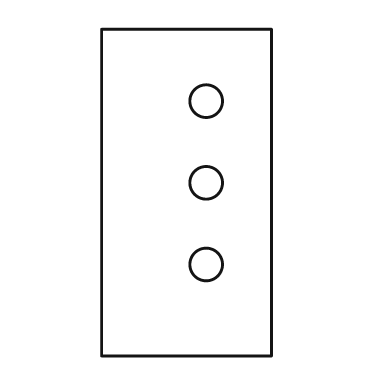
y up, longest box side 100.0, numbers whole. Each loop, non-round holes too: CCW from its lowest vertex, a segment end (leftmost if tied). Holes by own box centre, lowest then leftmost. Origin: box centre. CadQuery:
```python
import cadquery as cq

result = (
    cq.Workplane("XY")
    .moveTo(-26.0, -50.0)
    .lineTo(26.0, -50.0)
    .lineTo(26.0, 50.0)
    .lineTo(-26.0, 50.0)
    .close()
    .moveTo(6.0, -22.0)
    .circle(5.0)
    .moveTo(6.0, 3.0)
    .circle(5.0)
    .moveTo(6.0, 28.0)
    .circle(5.0)
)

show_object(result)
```